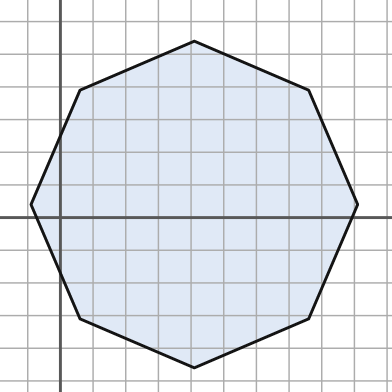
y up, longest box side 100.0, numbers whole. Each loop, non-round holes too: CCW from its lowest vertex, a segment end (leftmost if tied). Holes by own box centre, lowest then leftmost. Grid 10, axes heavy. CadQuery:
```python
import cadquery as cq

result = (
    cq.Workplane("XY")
    .moveTo(41.0, -46.0)
    .lineTo(76.0, -31.0)
    .lineTo(91.0, 4.0)
    .lineTo(76.0, 39.0)
    .lineTo(41.0, 54.0)
    .lineTo(6.0, 39.0)
    .lineTo(-9.0, 4.0)
    .lineTo(6.0, -31.0)
    .close()
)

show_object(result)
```